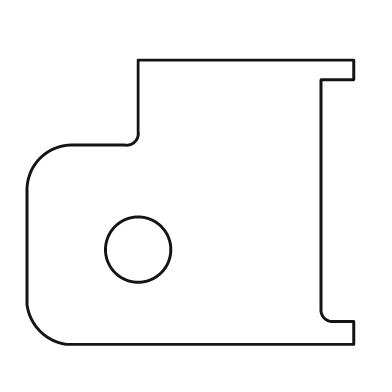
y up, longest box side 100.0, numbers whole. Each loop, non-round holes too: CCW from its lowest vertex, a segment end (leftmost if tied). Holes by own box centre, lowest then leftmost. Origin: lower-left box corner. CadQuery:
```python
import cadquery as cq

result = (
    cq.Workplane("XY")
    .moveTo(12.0, 0.0)
    .lineTo(100.0, 0.0)
    .lineTo(100.0, 7.0)
    .lineTo(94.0, 7.0)
    .threePointArc((91.0, 8.0), (90.0, 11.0))
    .lineTo(90.0, 81.0)
    .lineTo(100.0, 81.0)
    .lineTo(100.0, 87.0)
    .lineTo(34.0, 87.0)
    .lineTo(34.0, 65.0)
    .threePointArc((33.0, 62.0), (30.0, 61.0))
    .lineTo(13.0, 61.0)
    .threePointArc((4.0, 57.0), (0.0, 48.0))
    .lineTo(0.0, 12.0)
    .threePointArc((4.0, 4.0), (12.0, 0.0))
    .close()
    .moveTo(34.0, 29.0)
    .circle(10.0)
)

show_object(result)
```